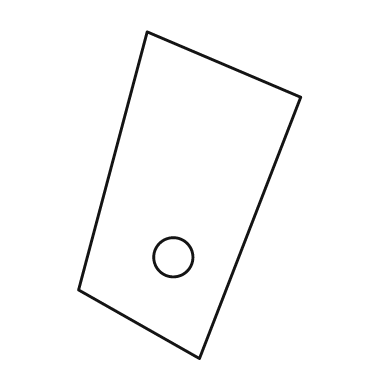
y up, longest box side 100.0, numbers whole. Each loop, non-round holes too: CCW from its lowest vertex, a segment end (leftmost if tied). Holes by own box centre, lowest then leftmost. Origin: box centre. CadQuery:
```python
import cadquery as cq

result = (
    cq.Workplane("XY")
    .moveTo(3.0, -50.0)
    .lineTo(34.0, 30.0)
    .lineTo(-13.0, 50.0)
    .lineTo(-34.0, -29.0)
    .close()
    .moveTo(-5.0, -19.0)
    .circle(6.0)
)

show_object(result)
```